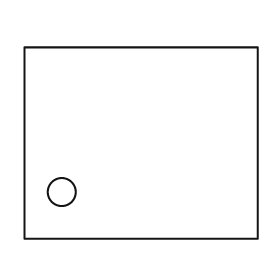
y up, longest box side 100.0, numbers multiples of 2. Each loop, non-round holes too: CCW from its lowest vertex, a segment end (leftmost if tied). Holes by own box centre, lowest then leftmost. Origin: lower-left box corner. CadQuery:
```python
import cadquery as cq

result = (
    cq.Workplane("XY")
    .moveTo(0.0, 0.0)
    .lineTo(100.0, 0.0)
    .lineTo(100.0, 82.0)
    .lineTo(0.0, 82.0)
    .close()
    .moveTo(16.0, 20.0)
    .circle(6.0)
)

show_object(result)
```